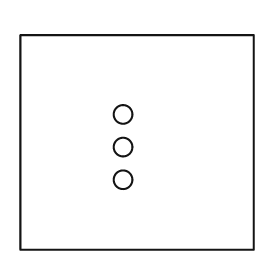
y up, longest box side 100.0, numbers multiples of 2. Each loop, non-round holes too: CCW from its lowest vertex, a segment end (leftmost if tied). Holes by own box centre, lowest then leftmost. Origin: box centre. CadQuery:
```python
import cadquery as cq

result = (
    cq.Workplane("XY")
    .moveTo(-50.0, -46.0)
    .lineTo(50.0, -46.0)
    .lineTo(50.0, 46.0)
    .lineTo(-50.0, 46.0)
    .close()
    .moveTo(-6.0, -16.0)
    .circle(4.0)
    .moveTo(-6.0, -2.0)
    .circle(4.0)
    .moveTo(-6.0, 12.0)
    .circle(4.0)
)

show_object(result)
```